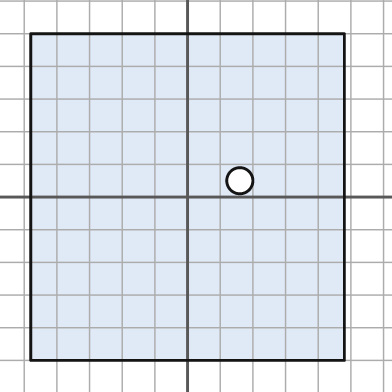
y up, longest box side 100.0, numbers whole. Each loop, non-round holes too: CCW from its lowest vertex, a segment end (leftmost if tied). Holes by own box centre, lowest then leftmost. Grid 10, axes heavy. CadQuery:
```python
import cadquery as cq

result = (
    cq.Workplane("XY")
    .moveTo(-48.0, -50.0)
    .lineTo(48.0, -50.0)
    .lineTo(48.0, 50.0)
    .lineTo(-48.0, 50.0)
    .close()
    .moveTo(16.0, 5.0)
    .circle(4.0)
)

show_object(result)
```